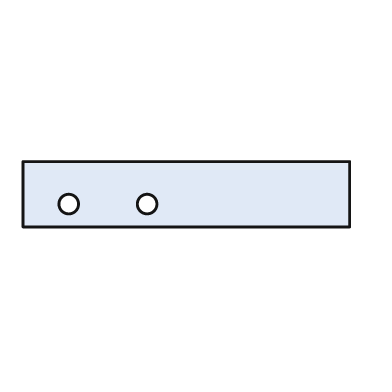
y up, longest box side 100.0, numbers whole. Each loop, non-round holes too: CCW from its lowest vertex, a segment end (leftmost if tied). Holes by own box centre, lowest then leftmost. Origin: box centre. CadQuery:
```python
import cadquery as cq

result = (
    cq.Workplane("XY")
    .moveTo(-50.0, -10.0)
    .lineTo(50.0, -10.0)
    .lineTo(50.0, 10.0)
    .lineTo(-50.0, 10.0)
    .close()
    .moveTo(-36.0, -3.0)
    .circle(3.0)
    .moveTo(-12.0, -3.0)
    .circle(3.0)
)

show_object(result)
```